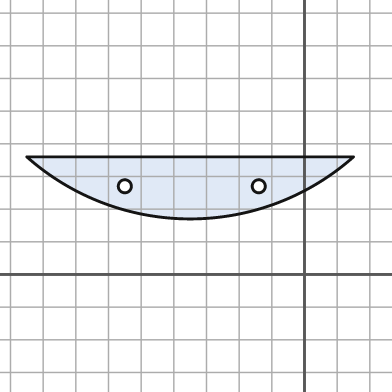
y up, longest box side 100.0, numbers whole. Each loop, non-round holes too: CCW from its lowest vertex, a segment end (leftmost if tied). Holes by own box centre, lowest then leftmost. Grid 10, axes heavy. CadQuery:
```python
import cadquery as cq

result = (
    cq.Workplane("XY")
    .moveTo(-85.0, 36.0)
    .threePointArc((-35.0, 17.0), (15.0, 36.0))
    .close()
    .moveTo(-55.0, 27.0)
    .circle(2.0)
    .moveTo(-14.0, 27.0)
    .circle(2.0)
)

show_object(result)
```